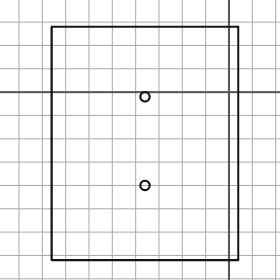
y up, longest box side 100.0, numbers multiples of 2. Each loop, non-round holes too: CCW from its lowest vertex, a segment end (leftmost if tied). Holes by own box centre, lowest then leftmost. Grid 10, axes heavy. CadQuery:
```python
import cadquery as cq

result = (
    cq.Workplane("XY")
    .moveTo(-76.0, -72.0)
    .lineTo(4.0, -72.0)
    .lineTo(4.0, 28.0)
    .lineTo(-76.0, 28.0)
    .close()
    .moveTo(-36.0, -40.0)
    .circle(2.0)
    .moveTo(-36.0, -2.0)
    .circle(2.0)
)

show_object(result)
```